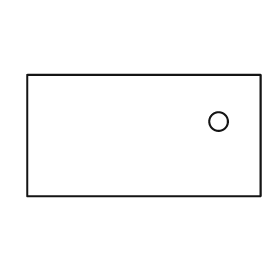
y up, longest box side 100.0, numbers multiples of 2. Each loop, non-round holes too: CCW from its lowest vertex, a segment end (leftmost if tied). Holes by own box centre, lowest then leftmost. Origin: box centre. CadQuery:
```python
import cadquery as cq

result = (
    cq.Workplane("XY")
    .moveTo(-50.0, -26.0)
    .lineTo(50.0, -26.0)
    .lineTo(50.0, 26.0)
    .lineTo(-50.0, 26.0)
    .close()
    .moveTo(32.0, 6.0)
    .circle(4.0)
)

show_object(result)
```